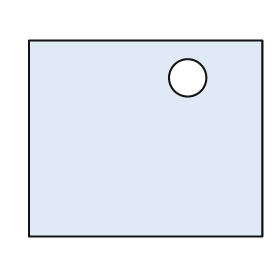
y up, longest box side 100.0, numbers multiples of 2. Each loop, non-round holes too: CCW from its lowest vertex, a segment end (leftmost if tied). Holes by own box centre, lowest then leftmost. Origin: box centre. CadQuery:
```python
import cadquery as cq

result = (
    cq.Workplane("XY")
    .moveTo(-50.0, -42.0)
    .lineTo(50.0, -42.0)
    .lineTo(50.0, 42.0)
    .lineTo(-50.0, 42.0)
    .close()
    .moveTo(18.0, 26.0)
    .circle(8.0)
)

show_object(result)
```